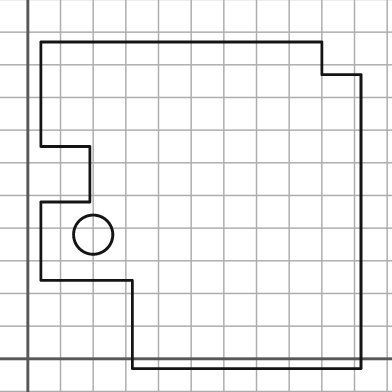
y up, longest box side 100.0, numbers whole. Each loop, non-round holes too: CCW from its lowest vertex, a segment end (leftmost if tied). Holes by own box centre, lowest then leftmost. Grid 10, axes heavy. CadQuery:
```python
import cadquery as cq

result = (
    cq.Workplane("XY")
    .moveTo(32.0, -3.0)
    .lineTo(102.0, -3.0)
    .lineTo(102.0, 87.0)
    .lineTo(90.0, 87.0)
    .lineTo(90.0, 97.0)
    .lineTo(4.0, 97.0)
    .lineTo(4.0, 65.0)
    .lineTo(19.0, 65.0)
    .lineTo(19.0, 48.0)
    .lineTo(4.0, 48.0)
    .lineTo(4.0, 24.0)
    .lineTo(32.0, 24.0)
    .close()
    .moveTo(20.0, 38.0)
    .circle(6.0)
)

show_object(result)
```